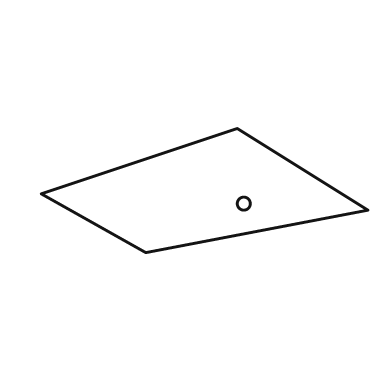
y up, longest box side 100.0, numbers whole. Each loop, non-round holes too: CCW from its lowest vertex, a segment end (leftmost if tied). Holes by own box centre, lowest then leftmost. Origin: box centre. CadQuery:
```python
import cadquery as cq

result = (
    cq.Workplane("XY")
    .moveTo(-18.0, -19.0)
    .lineTo(50.0, -6.0)
    .lineTo(10.0, 19.0)
    .lineTo(-50.0, -1.0)
    .close()
    .moveTo(12.0, -4.0)
    .circle(2.0)
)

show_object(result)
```